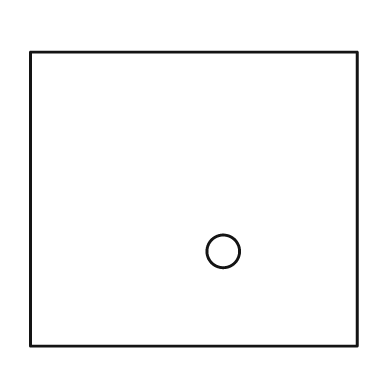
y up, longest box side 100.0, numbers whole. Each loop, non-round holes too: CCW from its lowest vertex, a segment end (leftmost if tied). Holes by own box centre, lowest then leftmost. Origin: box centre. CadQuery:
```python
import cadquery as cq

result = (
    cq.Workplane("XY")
    .moveTo(-50.0, -45.0)
    .lineTo(50.0, -45.0)
    .lineTo(50.0, 45.0)
    .lineTo(-50.0, 45.0)
    .close()
    .moveTo(9.0, -16.0)
    .circle(5.0)
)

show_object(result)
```